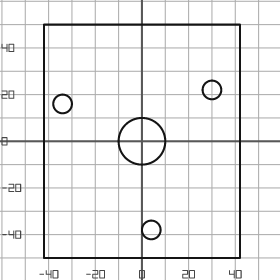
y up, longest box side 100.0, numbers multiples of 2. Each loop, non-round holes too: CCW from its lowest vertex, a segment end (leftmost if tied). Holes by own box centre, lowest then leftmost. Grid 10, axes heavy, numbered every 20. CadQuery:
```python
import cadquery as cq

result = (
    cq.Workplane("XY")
    .moveTo(-42.0, -50.0)
    .lineTo(42.0, -50.0)
    .lineTo(42.0, 50.0)
    .lineTo(-42.0, 50.0)
    .close()
    .moveTo(4.0, -38.0)
    .circle(4.0)
    .moveTo(0.0, 0.0)
    .circle(10.0)
    .moveTo(-34.0, 16.0)
    .circle(4.0)
    .moveTo(30.0, 22.0)
    .circle(4.0)
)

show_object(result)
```